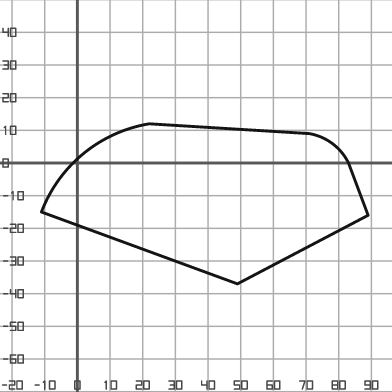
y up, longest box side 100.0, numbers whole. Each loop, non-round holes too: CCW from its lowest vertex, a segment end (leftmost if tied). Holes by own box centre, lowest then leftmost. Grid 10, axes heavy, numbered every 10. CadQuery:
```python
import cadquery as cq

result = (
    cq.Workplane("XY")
    .moveTo(49.0, -37.0)
    .lineTo(89.0, -16.0)
    .lineTo(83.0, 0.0)
    .threePointArc((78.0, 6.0), (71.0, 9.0))
    .lineTo(22.0, 12.0)
    .threePointArc((2.0, 3.0), (-11.0, -15.0))
    .close()
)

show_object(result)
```